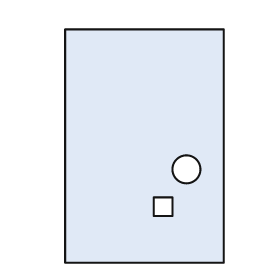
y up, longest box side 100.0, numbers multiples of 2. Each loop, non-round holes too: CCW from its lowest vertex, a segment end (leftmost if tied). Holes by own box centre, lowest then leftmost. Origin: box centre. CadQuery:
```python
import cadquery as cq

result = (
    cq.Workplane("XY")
    .moveTo(-34.0, -50.0)
    .lineTo(34.0, -50.0)
    .lineTo(34.0, 50.0)
    .lineTo(-34.0, 50.0)
    .close()
    .moveTo(4.0, -30.0)
    .lineTo(12.0, -30.0)
    .lineTo(12.0, -22.0)
    .lineTo(4.0, -22.0)
    .close()
    .moveTo(18.0, -10.0)
    .circle(6.0)
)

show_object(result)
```